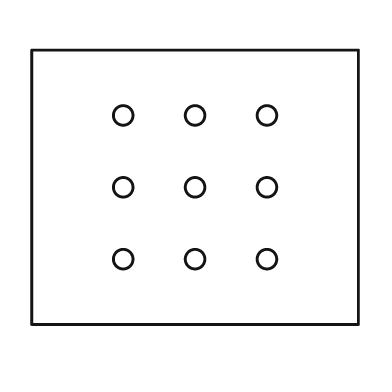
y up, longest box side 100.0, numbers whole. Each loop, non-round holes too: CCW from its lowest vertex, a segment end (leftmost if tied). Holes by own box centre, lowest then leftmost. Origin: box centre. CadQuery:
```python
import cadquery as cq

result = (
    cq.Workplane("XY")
    .moveTo(-50.0, -42.0)
    .lineTo(50.0, -42.0)
    .lineTo(50.0, 42.0)
    .lineTo(-50.0, 42.0)
    .close()
    .moveTo(-22.0, -22.0)
    .circle(3.0)
    .moveTo(0.0, -22.0)
    .circle(3.0)
    .moveTo(22.0, -22.0)
    .circle(3.0)
    .moveTo(-22.0, 0.0)
    .circle(3.0)
    .moveTo(0.0, 0.0)
    .circle(3.0)
    .moveTo(22.0, 0.0)
    .circle(3.0)
    .moveTo(-22.0, 22.0)
    .circle(3.0)
    .moveTo(0.0, 22.0)
    .circle(3.0)
    .moveTo(22.0, 22.0)
    .circle(3.0)
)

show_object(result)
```